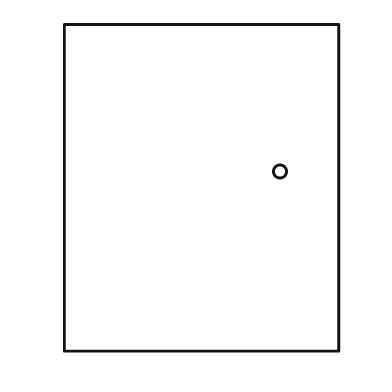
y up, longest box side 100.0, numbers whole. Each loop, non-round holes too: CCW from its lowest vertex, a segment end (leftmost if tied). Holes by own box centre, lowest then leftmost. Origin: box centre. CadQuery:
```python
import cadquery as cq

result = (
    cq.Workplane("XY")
    .moveTo(-42.0, -50.0)
    .lineTo(42.0, -50.0)
    .lineTo(42.0, 50.0)
    .lineTo(-42.0, 50.0)
    .close()
    .moveTo(24.0, 5.0)
    .circle(2.0)
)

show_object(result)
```